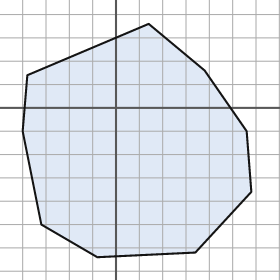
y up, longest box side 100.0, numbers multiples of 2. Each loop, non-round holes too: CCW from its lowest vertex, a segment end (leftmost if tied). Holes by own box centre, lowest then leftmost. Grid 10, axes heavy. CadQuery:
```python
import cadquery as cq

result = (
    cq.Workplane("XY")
    .moveTo(-8.0, -64.0)
    .lineTo(34.0, -62.0)
    .lineTo(58.0, -36.0)
    .lineTo(56.0, -10.0)
    .lineTo(38.0, 16.0)
    .lineTo(14.0, 36.0)
    .lineTo(-38.0, 14.0)
    .lineTo(-40.0, -10.0)
    .lineTo(-32.0, -50.0)
    .close()
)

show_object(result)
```